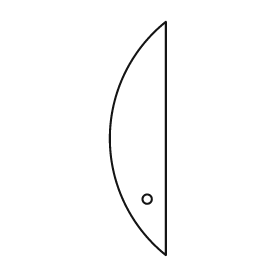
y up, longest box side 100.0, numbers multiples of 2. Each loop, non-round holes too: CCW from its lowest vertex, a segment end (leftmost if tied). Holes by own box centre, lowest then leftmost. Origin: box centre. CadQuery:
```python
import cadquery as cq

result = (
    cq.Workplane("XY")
    .moveTo(12.0, -50.0)
    .lineTo(12.0, 50.0)
    .threePointArc((-12.0, 0.0), (12.0, -50.0))
    .close()
    .moveTo(4.0, -26.0)
    .circle(2.0)
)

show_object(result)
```